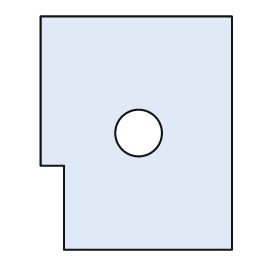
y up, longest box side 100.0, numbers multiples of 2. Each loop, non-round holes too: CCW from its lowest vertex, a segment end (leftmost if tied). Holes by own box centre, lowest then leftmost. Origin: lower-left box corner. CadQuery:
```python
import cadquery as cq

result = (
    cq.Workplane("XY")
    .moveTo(10.0, 0.0)
    .lineTo(82.0, 0.0)
    .lineTo(82.0, 100.0)
    .lineTo(0.0, 100.0)
    .lineTo(0.0, 36.0)
    .lineTo(10.0, 36.0)
    .close()
    .moveTo(42.0, 50.0)
    .circle(10.0)
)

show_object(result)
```